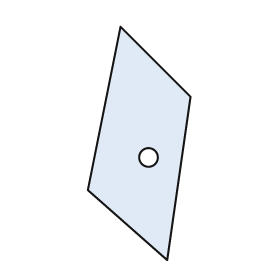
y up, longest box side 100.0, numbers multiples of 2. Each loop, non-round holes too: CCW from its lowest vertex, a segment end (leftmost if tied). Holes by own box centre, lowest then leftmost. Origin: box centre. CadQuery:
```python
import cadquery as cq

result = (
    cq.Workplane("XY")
    .moveTo(12.0, -50.0)
    .lineTo(22.0, 20.0)
    .lineTo(-8.0, 50.0)
    .lineTo(-22.0, -20.0)
    .close()
    .moveTo(4.0, -6.0)
    .circle(4.0)
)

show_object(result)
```